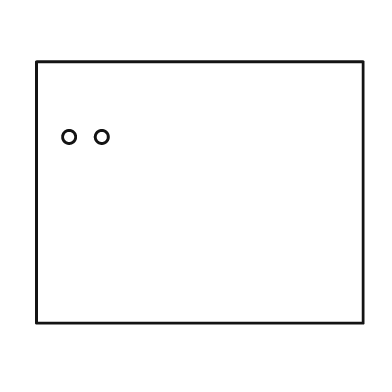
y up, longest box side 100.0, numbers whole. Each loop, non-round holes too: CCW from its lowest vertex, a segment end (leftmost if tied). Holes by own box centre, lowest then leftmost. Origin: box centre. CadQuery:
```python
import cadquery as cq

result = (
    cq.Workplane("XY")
    .moveTo(-50.0, -40.0)
    .lineTo(50.0, -40.0)
    .lineTo(50.0, 40.0)
    .lineTo(-50.0, 40.0)
    .close()
    .moveTo(-40.0, 17.0)
    .circle(2.0)
    .moveTo(-30.0, 17.0)
    .circle(2.0)
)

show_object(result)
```